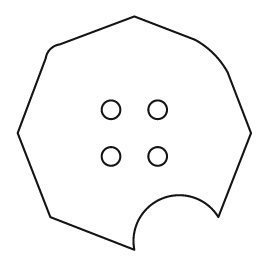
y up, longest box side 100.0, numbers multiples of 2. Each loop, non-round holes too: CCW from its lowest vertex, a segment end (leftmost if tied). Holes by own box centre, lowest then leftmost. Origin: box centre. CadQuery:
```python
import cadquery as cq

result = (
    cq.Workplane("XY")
    .moveTo(0.0, -50.0)
    .threePointArc((12.0, -28.0), (36.0, -36.0))
    .lineTo(50.0, 0.0)
    .lineTo(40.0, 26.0)
    .threePointArc((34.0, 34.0), (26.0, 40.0))
    .lineTo(0.0, 50.0)
    .lineTo(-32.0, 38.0)
    .threePointArc((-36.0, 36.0), (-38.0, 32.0))
    .lineTo(-50.0, 0.0)
    .lineTo(-36.0, -36.0)
    .close()
    .moveTo(-10.0, -10.0)
    .circle(4.0)
    .moveTo(10.0, -10.0)
    .circle(4.0)
    .moveTo(-10.0, 10.0)
    .circle(4.0)
    .moveTo(10.0, 10.0)
    .circle(4.0)
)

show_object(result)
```